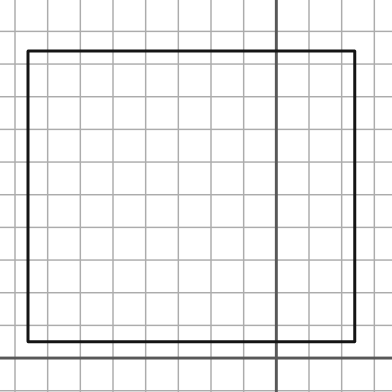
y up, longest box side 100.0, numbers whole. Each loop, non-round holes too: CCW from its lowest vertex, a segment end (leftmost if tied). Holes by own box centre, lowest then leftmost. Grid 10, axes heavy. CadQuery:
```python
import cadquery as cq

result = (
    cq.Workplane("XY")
    .moveTo(-76.0, 5.0)
    .lineTo(24.0, 5.0)
    .lineTo(24.0, 94.0)
    .lineTo(-76.0, 94.0)
    .close()
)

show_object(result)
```